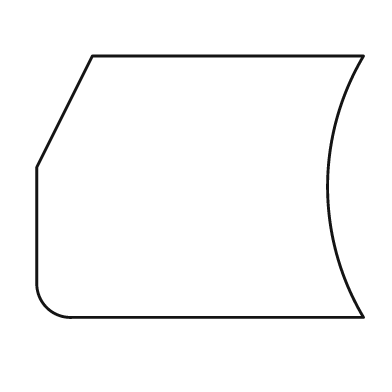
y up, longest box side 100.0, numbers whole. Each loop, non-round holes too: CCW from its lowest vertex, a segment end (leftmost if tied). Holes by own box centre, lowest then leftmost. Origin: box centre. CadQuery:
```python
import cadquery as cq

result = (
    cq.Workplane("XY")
    .moveTo(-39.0, -40.0)
    .lineTo(50.0, -40.0)
    .threePointArc((39.0, 0.0), (50.0, 40.0))
    .lineTo(-33.0, 40.0)
    .lineTo(-50.0, 6.0)
    .lineTo(-50.0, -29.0)
    .threePointArc((-47.0, -37.0), (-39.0, -40.0))
    .close()
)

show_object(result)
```